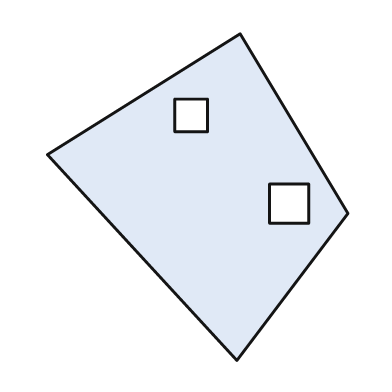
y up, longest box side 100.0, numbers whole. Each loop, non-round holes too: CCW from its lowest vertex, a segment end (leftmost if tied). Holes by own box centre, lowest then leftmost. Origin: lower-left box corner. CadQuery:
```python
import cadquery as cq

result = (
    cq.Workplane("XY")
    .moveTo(58.0, 0.0)
    .lineTo(92.0, 45.0)
    .lineTo(59.0, 100.0)
    .lineTo(0.0, 63.0)
    .close()
    .moveTo(68.0, 42.0)
    .lineTo(80.0, 42.0)
    .lineTo(80.0, 54.0)
    .lineTo(68.0, 54.0)
    .close()
    .moveTo(39.0, 70.0)
    .lineTo(49.0, 70.0)
    .lineTo(49.0, 80.0)
    .lineTo(39.0, 80.0)
    .close()
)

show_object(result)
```